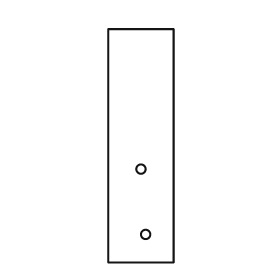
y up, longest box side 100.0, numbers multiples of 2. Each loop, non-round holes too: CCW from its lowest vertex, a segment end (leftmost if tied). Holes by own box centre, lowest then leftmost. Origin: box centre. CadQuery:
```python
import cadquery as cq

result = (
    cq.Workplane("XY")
    .moveTo(-14.0, -50.0)
    .lineTo(14.0, -50.0)
    .lineTo(14.0, 50.0)
    .lineTo(-14.0, 50.0)
    .close()
    .moveTo(2.0, -38.0)
    .circle(2.0)
    .moveTo(0.0, -10.0)
    .circle(2.0)
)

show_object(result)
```